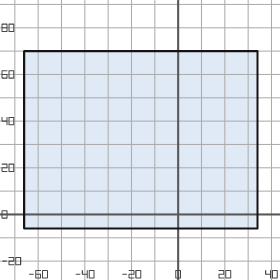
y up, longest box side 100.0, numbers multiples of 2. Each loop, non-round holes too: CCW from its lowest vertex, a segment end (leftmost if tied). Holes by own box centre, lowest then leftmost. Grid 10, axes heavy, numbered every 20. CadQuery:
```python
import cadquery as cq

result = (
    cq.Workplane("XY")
    .moveTo(-66.0, -6.0)
    .lineTo(34.0, -6.0)
    .lineTo(34.0, 70.0)
    .lineTo(-66.0, 70.0)
    .close()
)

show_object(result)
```